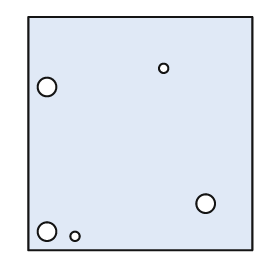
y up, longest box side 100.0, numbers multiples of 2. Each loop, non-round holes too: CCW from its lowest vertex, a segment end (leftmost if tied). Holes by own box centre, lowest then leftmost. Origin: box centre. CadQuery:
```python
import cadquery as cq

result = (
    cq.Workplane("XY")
    .moveTo(-48.0, -50.0)
    .lineTo(48.0, -50.0)
    .lineTo(48.0, 50.0)
    .lineTo(-48.0, 50.0)
    .close()
    .moveTo(-28.0, -44.0)
    .circle(2.0)
    .moveTo(-40.0, -42.0)
    .circle(4.0)
    .moveTo(28.0, -30.0)
    .circle(4.0)
    .moveTo(-40.0, 20.0)
    .circle(4.0)
    .moveTo(10.0, 28.0)
    .circle(2.0)
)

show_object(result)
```